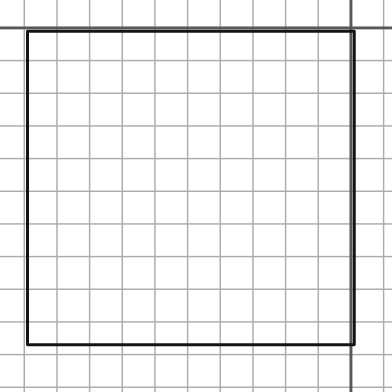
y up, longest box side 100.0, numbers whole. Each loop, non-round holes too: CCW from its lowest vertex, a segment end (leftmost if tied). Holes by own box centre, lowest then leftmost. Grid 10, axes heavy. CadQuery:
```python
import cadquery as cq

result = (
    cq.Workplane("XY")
    .moveTo(-99.0, -97.0)
    .lineTo(1.0, -97.0)
    .lineTo(1.0, -1.0)
    .lineTo(-99.0, -1.0)
    .close()
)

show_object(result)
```